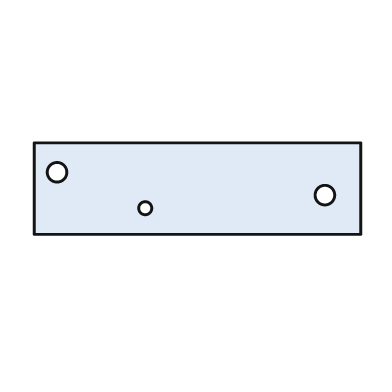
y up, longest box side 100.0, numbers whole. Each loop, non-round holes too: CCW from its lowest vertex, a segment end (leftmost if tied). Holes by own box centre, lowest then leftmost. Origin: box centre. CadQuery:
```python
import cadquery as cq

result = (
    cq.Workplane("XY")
    .moveTo(-50.0, -14.0)
    .lineTo(50.0, -14.0)
    .lineTo(50.0, 14.0)
    .lineTo(-50.0, 14.0)
    .close()
    .moveTo(-16.0, -6.0)
    .circle(2.0)
    .moveTo(39.0, -2.0)
    .circle(3.0)
    .moveTo(-43.0, 5.0)
    .circle(3.0)
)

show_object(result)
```